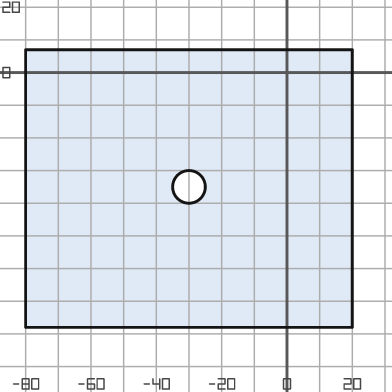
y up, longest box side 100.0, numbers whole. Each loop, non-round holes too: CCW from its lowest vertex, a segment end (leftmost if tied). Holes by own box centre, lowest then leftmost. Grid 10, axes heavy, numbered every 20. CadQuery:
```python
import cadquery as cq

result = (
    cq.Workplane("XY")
    .moveTo(-80.0, -78.0)
    .lineTo(20.0, -78.0)
    .lineTo(20.0, 7.0)
    .lineTo(-80.0, 7.0)
    .close()
    .moveTo(-30.0, -35.0)
    .circle(5.0)
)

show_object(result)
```